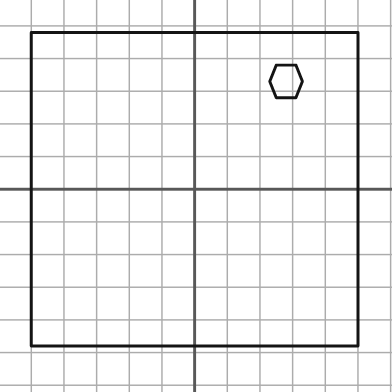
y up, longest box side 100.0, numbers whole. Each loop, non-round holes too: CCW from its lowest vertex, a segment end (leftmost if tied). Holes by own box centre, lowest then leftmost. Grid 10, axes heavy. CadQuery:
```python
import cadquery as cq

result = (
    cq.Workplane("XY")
    .moveTo(-50.0, -48.0)
    .lineTo(50.0, -48.0)
    .lineTo(50.0, 48.0)
    .lineTo(-50.0, 48.0)
    .close()
    .moveTo(25.0, 28.0)
    .lineTo(31.0, 28.0)
    .lineTo(33.0, 33.0)
    .lineTo(31.0, 38.0)
    .lineTo(25.0, 38.0)
    .lineTo(23.0, 33.0)
    .close()
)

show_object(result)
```